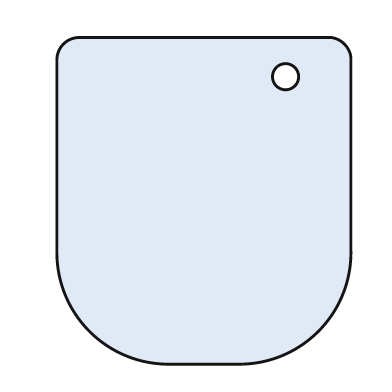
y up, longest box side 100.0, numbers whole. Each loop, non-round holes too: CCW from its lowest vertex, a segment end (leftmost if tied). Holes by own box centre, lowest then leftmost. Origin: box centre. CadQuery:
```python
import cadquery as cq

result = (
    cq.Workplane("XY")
    .moveTo(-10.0, -50.0)
    .lineTo(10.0, -50.0)
    .threePointArc((35.0, -40.0), (45.0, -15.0))
    .lineTo(45.0, 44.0)
    .threePointArc((43.0, 48.0), (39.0, 50.0))
    .lineTo(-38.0, 50.0)
    .threePointArc((-43.0, 48.0), (-45.0, 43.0))
    .lineTo(-45.0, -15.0)
    .threePointArc((-35.0, -40.0), (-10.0, -50.0))
    .close()
    .moveTo(25.0, 38.0)
    .circle(4.0)
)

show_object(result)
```